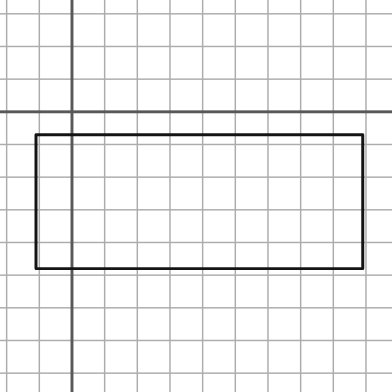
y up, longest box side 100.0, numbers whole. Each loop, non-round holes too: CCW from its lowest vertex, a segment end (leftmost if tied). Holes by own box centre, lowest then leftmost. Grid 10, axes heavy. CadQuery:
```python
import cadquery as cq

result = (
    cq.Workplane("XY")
    .moveTo(-11.0, -48.0)
    .lineTo(89.0, -48.0)
    .lineTo(89.0, -7.0)
    .lineTo(-11.0, -7.0)
    .close()
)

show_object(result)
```